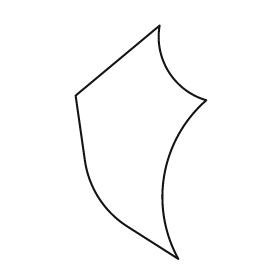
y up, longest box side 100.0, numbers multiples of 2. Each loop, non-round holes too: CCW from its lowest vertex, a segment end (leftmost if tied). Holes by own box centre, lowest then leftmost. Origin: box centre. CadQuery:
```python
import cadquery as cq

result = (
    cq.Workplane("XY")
    .moveTo(16.0, -50.0)
    .threePointArc((10.0, -14.0), (28.0, 18.0))
    .threePointArc((12.0, 30.0), (8.0, 50.0))
    .lineTo(-28.0, 20.0)
    .lineTo(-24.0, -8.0)
    .threePointArc((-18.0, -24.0), (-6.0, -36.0))
    .close()
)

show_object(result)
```